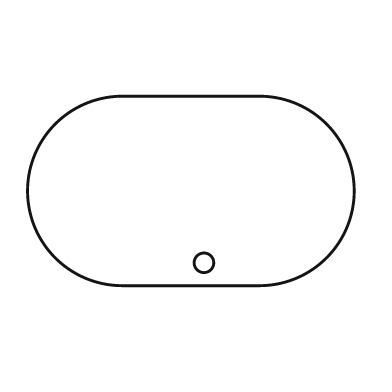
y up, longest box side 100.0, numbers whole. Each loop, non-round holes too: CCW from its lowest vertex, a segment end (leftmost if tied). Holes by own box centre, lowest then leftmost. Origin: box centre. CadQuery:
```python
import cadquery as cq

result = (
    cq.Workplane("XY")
    .moveTo(-21.0, -29.0)
    .lineTo(21.0, -29.0)
    .threePointArc((50.0, 0.0), (21.0, 29.0))
    .lineTo(-21.0, 29.0)
    .threePointArc((-50.0, 0.0), (-21.0, -29.0))
    .close()
    .moveTo(4.0, -22.0)
    .circle(3.0)
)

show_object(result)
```